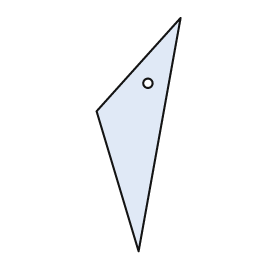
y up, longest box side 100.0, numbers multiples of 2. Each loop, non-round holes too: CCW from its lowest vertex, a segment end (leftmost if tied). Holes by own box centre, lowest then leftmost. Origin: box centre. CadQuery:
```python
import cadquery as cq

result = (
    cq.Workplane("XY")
    .moveTo(0.0, -50.0)
    .lineTo(18.0, 50.0)
    .lineTo(-18.0, 10.0)
    .close()
    .moveTo(4.0, 22.0)
    .circle(2.0)
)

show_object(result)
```